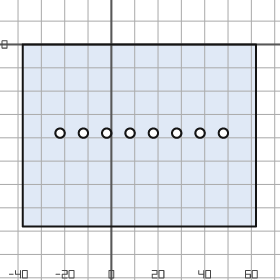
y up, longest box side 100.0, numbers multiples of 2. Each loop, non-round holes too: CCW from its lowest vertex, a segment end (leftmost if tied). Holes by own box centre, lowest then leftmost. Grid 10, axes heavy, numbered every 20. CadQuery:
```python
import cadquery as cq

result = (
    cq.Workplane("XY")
    .moveTo(-38.0, -78.0)
    .lineTo(62.0, -78.0)
    .lineTo(62.0, 0.0)
    .lineTo(-38.0, 0.0)
    .close()
    .moveTo(-22.0, -38.0)
    .circle(2.0)
    .moveTo(-12.0, -38.0)
    .circle(2.0)
    .moveTo(-2.0, -38.0)
    .circle(2.0)
    .moveTo(8.0, -38.0)
    .circle(2.0)
    .moveTo(18.0, -38.0)
    .circle(2.0)
    .moveTo(28.0, -38.0)
    .circle(2.0)
    .moveTo(38.0, -38.0)
    .circle(2.0)
    .moveTo(48.0, -38.0)
    .circle(2.0)
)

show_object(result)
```